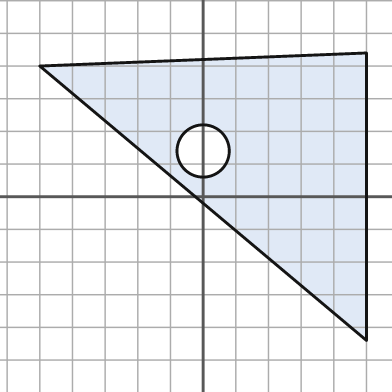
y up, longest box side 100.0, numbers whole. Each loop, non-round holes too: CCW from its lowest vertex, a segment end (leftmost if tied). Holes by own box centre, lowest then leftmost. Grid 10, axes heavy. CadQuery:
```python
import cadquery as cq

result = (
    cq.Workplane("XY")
    .moveTo(50.0, -44.0)
    .lineTo(50.0, 44.0)
    .lineTo(-50.0, 40.0)
    .close()
    .moveTo(0.0, 14.0)
    .circle(8.0)
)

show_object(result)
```